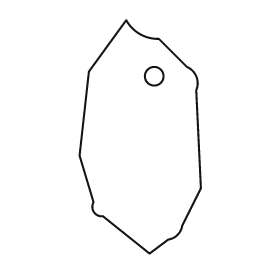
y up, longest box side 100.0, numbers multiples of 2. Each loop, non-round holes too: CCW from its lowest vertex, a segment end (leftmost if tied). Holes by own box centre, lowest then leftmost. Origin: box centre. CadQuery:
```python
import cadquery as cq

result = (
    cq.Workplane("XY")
    .moveTo(4.0, -50.0)
    .lineTo(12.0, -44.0)
    .threePointArc((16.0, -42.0), (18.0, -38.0))
    .lineTo(26.0, -22.0)
    .lineTo(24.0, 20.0)
    .threePointArc((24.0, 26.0), (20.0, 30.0))
    .lineTo(8.0, 42.0)
    .threePointArc((0.0, 44.0), (-6.0, 50.0))
    .lineTo(-22.0, 28.0)
    .lineTo(-26.0, -8.0)
    .lineTo(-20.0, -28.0)
    .threePointArc((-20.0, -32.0), (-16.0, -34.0))
    .close()
    .moveTo(6.0, 26.0)
    .circle(4.0)
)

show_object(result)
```